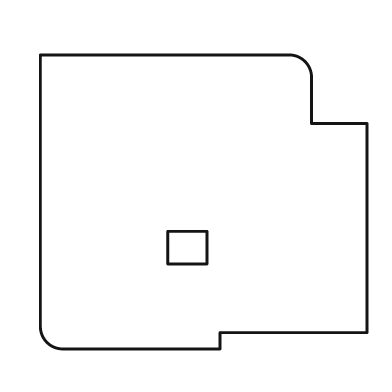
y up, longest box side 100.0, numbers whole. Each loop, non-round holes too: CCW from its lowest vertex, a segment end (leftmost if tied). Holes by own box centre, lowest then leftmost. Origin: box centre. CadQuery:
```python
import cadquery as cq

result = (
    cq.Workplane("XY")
    .moveTo(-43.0, -45.0)
    .lineTo(5.0, -45.0)
    .lineTo(5.0, -40.0)
    .lineTo(50.0, -40.0)
    .lineTo(50.0, 24.0)
    .lineTo(33.0, 24.0)
    .lineTo(33.0, 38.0)
    .threePointArc((31.0, 43.0), (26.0, 45.0))
    .lineTo(-50.0, 45.0)
    .lineTo(-50.0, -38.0)
    .threePointArc((-48.0, -43.0), (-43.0, -45.0))
    .close()
    .moveTo(-11.0, -19.0)
    .lineTo(1.0, -19.0)
    .lineTo(1.0, -9.0)
    .lineTo(-11.0, -9.0)
    .close()
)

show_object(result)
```